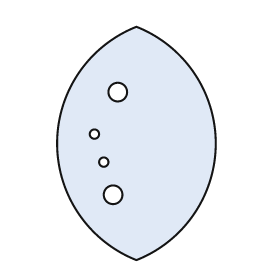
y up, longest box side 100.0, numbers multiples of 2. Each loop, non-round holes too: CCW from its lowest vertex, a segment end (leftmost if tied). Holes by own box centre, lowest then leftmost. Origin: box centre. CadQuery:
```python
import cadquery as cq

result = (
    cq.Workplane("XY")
    .moveTo(0.0, -50.0)
    .threePointArc((34.0, 0.0), (0.0, 50.0))
    .threePointArc((-34.0, 0.0), (0.0, -50.0))
    .close()
    .moveTo(-10.0, -22.0)
    .circle(4.0)
    .moveTo(-14.0, -8.0)
    .circle(2.0)
    .moveTo(-18.0, 4.0)
    .circle(2.0)
    .moveTo(-8.0, 22.0)
    .circle(4.0)
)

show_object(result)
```